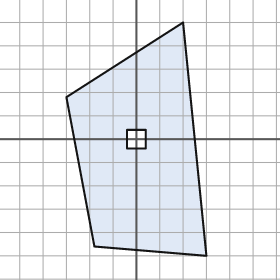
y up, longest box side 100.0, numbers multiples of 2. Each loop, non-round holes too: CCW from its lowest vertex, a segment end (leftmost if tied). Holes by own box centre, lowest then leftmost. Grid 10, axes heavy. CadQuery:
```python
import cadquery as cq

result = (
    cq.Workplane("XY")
    .moveTo(30.0, -50.0)
    .lineTo(20.0, 50.0)
    .lineTo(-30.0, 18.0)
    .lineTo(-18.0, -46.0)
    .close()
    .moveTo(-4.0, -4.0)
    .lineTo(4.0, -4.0)
    .lineTo(4.0, 4.0)
    .lineTo(-4.0, 4.0)
    .close()
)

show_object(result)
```